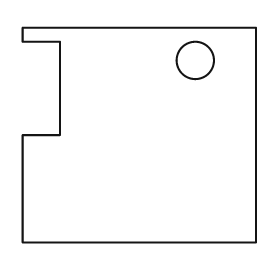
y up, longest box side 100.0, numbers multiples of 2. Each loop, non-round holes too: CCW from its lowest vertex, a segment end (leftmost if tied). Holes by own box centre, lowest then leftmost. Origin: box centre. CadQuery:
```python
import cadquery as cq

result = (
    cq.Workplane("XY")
    .moveTo(-50.0, -46.0)
    .lineTo(50.0, -46.0)
    .lineTo(50.0, 46.0)
    .lineTo(-50.0, 46.0)
    .lineTo(-50.0, 40.0)
    .lineTo(-34.0, 40.0)
    .lineTo(-34.0, 0.0)
    .lineTo(-50.0, 0.0)
    .close()
    .moveTo(24.0, 32.0)
    .circle(8.0)
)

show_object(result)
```